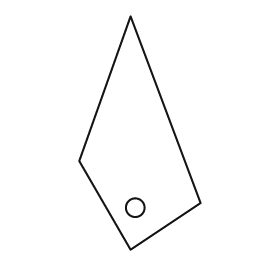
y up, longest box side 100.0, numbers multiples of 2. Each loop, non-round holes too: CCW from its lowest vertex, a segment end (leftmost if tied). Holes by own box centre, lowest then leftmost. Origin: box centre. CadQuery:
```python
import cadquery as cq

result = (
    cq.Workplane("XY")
    .moveTo(-4.0, -50.0)
    .lineTo(26.0, -30.0)
    .lineTo(-4.0, 50.0)
    .lineTo(-26.0, -12.0)
    .close()
    .moveTo(-2.0, -32.0)
    .circle(4.0)
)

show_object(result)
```